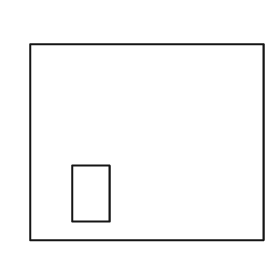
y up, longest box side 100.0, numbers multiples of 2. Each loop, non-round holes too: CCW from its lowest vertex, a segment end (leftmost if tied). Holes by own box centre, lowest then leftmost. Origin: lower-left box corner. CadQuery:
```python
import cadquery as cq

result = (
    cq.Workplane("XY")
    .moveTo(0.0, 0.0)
    .lineTo(100.0, 0.0)
    .lineTo(100.0, 84.0)
    .lineTo(0.0, 84.0)
    .close()
    .moveTo(18.0, 8.0)
    .lineTo(34.0, 8.0)
    .lineTo(34.0, 32.0)
    .lineTo(18.0, 32.0)
    .close()
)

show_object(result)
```